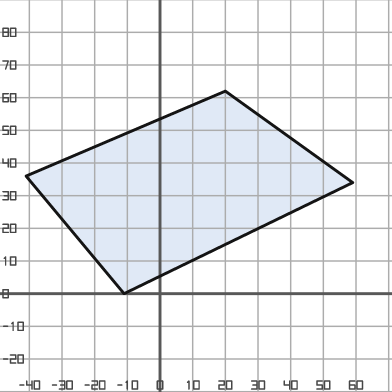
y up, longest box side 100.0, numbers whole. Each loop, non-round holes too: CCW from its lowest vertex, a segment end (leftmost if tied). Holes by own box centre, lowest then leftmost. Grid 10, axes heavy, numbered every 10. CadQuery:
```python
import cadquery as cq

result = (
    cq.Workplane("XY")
    .moveTo(-11.0, 0.0)
    .lineTo(59.0, 34.0)
    .lineTo(20.0, 62.0)
    .lineTo(-41.0, 36.0)
    .close()
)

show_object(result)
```